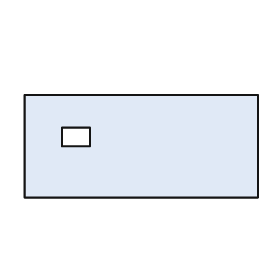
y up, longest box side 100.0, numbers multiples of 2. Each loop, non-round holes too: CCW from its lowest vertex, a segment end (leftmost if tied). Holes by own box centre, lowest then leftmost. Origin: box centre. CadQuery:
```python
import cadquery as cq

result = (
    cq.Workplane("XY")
    .moveTo(-50.0, -22.0)
    .lineTo(50.0, -22.0)
    .lineTo(50.0, 22.0)
    .lineTo(-50.0, 22.0)
    .close()
    .moveTo(-34.0, 0.0)
    .lineTo(-22.0, 0.0)
    .lineTo(-22.0, 8.0)
    .lineTo(-34.0, 8.0)
    .close()
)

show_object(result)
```